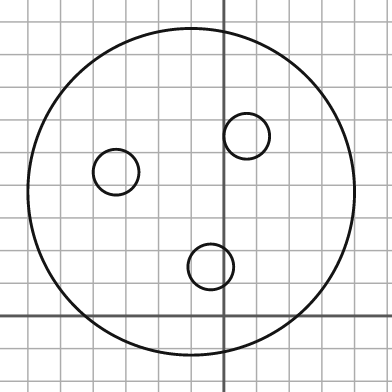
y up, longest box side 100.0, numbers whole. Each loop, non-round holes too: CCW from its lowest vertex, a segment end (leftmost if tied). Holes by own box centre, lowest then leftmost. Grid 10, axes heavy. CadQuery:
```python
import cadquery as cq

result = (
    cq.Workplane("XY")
    .moveTo(-10.0, 38.0)
    .circle(50.0)
    .moveTo(-4.0, 15.0)
    .circle(7.0)
    .moveTo(-33.0, 44.0)
    .circle(7.0)
    .moveTo(7.0, 55.0)
    .circle(7.0)
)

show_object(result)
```